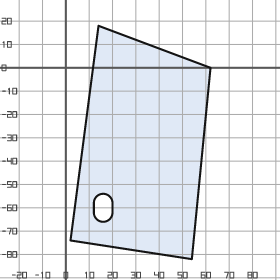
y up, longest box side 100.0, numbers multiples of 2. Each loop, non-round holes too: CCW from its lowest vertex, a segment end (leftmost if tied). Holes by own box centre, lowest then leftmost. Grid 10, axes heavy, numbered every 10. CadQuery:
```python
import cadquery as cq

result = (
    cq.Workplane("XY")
    .moveTo(54.0, -82.0)
    .lineTo(62.0, 0.0)
    .lineTo(14.0, 18.0)
    .lineTo(2.0, -74.0)
    .close()
    .moveTo(12.0, -62.0)
    .threePointArc((16.0, -66.0), (20.0, -62.0))
    .lineTo(20.0, -58.0)
    .threePointArc((16.0, -54.0), (12.0, -58.0))
    .close()
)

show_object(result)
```